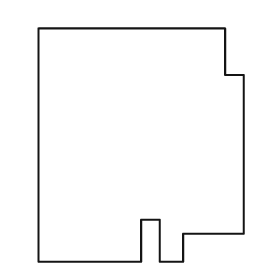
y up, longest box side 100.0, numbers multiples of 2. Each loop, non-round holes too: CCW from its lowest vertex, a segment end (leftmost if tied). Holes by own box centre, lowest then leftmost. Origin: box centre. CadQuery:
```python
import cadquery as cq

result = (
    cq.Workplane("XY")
    .moveTo(-44.0, -50.0)
    .lineTo(0.0, -50.0)
    .lineTo(0.0, -32.0)
    .lineTo(8.0, -32.0)
    .lineTo(8.0, -50.0)
    .lineTo(18.0, -50.0)
    .lineTo(18.0, -38.0)
    .lineTo(44.0, -38.0)
    .lineTo(44.0, 30.0)
    .lineTo(36.0, 30.0)
    .lineTo(36.0, 50.0)
    .lineTo(-44.0, 50.0)
    .close()
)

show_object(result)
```